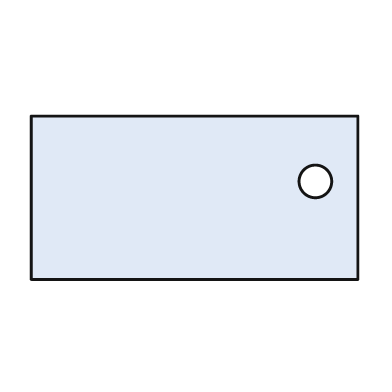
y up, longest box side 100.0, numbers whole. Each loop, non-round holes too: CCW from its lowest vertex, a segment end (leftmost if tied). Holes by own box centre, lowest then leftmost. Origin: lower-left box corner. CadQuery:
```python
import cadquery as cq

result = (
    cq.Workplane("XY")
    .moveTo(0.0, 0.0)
    .lineTo(100.0, 0.0)
    .lineTo(100.0, 50.0)
    .lineTo(0.0, 50.0)
    .close()
    .moveTo(87.0, 30.0)
    .circle(5.0)
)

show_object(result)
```